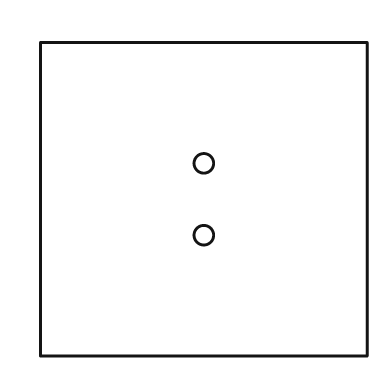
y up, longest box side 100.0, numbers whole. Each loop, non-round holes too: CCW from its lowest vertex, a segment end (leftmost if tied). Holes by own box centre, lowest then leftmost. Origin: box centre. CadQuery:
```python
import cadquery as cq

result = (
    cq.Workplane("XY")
    .moveTo(-50.0, -48.0)
    .lineTo(50.0, -48.0)
    .lineTo(50.0, 48.0)
    .lineTo(-50.0, 48.0)
    .close()
    .moveTo(0.0, -11.0)
    .circle(3.0)
    .moveTo(0.0, 11.0)
    .circle(3.0)
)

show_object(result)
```